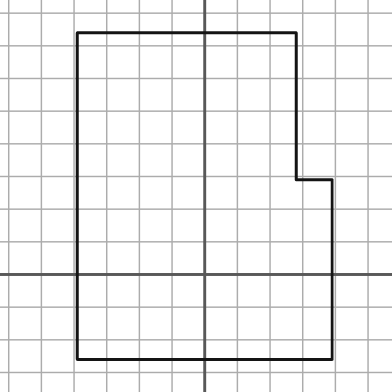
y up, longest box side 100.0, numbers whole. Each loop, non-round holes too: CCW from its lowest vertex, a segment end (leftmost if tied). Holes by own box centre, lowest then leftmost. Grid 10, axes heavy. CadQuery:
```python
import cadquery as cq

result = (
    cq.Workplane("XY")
    .moveTo(-39.0, -26.0)
    .lineTo(39.0, -26.0)
    .lineTo(39.0, 29.0)
    .lineTo(28.0, 29.0)
    .lineTo(28.0, 74.0)
    .lineTo(-39.0, 74.0)
    .close()
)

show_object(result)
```